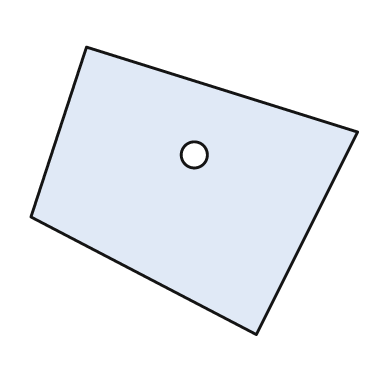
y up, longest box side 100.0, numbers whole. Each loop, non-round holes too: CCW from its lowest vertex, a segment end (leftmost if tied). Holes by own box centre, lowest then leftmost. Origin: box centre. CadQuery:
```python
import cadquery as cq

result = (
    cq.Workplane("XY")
    .moveTo(19.0, -44.0)
    .lineTo(50.0, 18.0)
    .lineTo(-33.0, 44.0)
    .lineTo(-50.0, -8.0)
    .close()
    .moveTo(0.0, 11.0)
    .circle(4.0)
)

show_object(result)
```